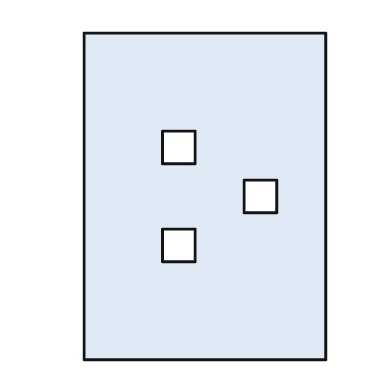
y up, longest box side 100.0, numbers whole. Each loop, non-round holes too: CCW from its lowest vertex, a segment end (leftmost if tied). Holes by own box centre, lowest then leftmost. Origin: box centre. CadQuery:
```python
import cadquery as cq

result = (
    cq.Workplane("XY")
    .moveTo(-37.0, -50.0)
    .lineTo(37.0, -50.0)
    .lineTo(37.0, 50.0)
    .lineTo(-37.0, 50.0)
    .close()
    .moveTo(-13.0, -20.0)
    .lineTo(-3.0, -20.0)
    .lineTo(-3.0, -10.0)
    .lineTo(-13.0, -10.0)
    .close()
    .moveTo(12.0, -5.0)
    .lineTo(22.0, -5.0)
    .lineTo(22.0, 5.0)
    .lineTo(12.0, 5.0)
    .close()
    .moveTo(-13.0, 10.0)
    .lineTo(-3.0, 10.0)
    .lineTo(-3.0, 20.0)
    .lineTo(-13.0, 20.0)
    .close()
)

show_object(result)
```